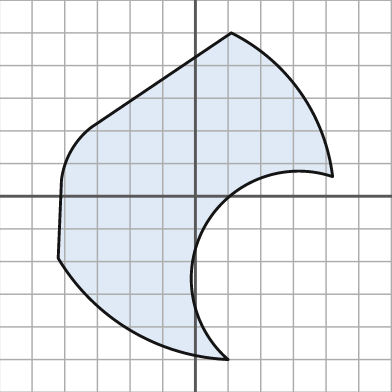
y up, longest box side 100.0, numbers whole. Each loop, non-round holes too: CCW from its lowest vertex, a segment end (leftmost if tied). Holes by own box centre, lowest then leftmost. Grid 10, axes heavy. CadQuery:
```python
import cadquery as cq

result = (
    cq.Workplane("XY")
    .moveTo(10.0, -50.0)
    .threePointArc((3.0, -9.0), (42.0, 6.0))
    .threePointArc((32.0, 32.0), (11.0, 50.0))
    .lineTo(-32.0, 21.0)
    .threePointArc((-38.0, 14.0), (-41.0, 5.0))
    .lineTo(-42.0, -19.0)
    .threePointArc((-20.0, -41.0), (10.0, -50.0))
    .close()
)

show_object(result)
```